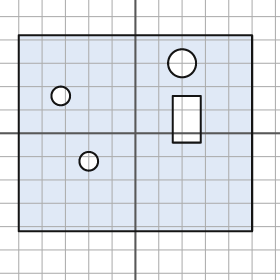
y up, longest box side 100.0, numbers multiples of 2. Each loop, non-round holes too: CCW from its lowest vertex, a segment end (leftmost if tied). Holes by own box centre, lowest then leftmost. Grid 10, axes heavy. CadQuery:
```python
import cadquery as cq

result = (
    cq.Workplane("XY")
    .moveTo(-50.0, -42.0)
    .lineTo(50.0, -42.0)
    .lineTo(50.0, 42.0)
    .lineTo(-50.0, 42.0)
    .close()
    .moveTo(-20.0, -12.0)
    .circle(4.0)
    .moveTo(16.0, -4.0)
    .lineTo(28.0, -4.0)
    .lineTo(28.0, 16.0)
    .lineTo(16.0, 16.0)
    .close()
    .moveTo(-32.0, 16.0)
    .circle(4.0)
    .moveTo(20.0, 30.0)
    .circle(6.0)
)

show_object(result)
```